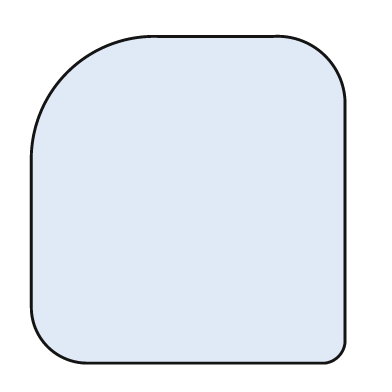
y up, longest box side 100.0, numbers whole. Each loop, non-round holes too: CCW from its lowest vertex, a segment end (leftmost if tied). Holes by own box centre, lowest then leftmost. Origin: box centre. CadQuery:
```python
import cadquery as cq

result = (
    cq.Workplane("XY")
    .moveTo(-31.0, -50.0)
    .lineTo(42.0, -50.0)
    .threePointArc((46.0, -48.0), (48.0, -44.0))
    .lineTo(48.0, 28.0)
    .threePointArc((42.0, 44.0), (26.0, 50.0))
    .lineTo(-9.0, 50.0)
    .threePointArc((-37.0, 39.0), (-48.0, 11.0))
    .lineTo(-48.0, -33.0)
    .threePointArc((-43.0, -45.0), (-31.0, -50.0))
    .close()
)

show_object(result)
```